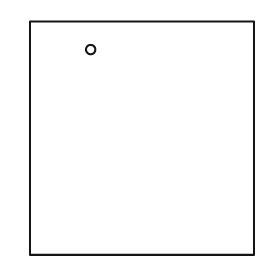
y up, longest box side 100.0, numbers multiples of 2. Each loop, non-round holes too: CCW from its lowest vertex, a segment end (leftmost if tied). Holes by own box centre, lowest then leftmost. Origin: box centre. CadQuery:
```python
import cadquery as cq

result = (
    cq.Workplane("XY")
    .moveTo(-48.0, -50.0)
    .lineTo(48.0, -50.0)
    .lineTo(48.0, 50.0)
    .lineTo(-48.0, 50.0)
    .close()
    .moveTo(-22.0, 38.0)
    .circle(2.0)
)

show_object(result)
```